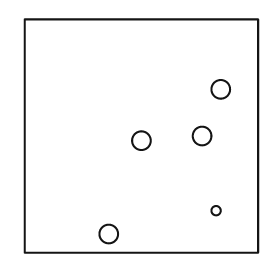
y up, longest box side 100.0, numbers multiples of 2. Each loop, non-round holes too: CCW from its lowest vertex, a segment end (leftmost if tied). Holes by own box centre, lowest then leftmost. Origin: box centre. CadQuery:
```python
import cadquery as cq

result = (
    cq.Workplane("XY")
    .moveTo(-50.0, -50.0)
    .lineTo(50.0, -50.0)
    .lineTo(50.0, 50.0)
    .lineTo(-50.0, 50.0)
    .close()
    .moveTo(-14.0, -42.0)
    .circle(4.0)
    .moveTo(32.0, -32.0)
    .circle(2.0)
    .moveTo(0.0, -2.0)
    .circle(4.0)
    .moveTo(26.0, 0.0)
    .circle(4.0)
    .moveTo(34.0, 20.0)
    .circle(4.0)
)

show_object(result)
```